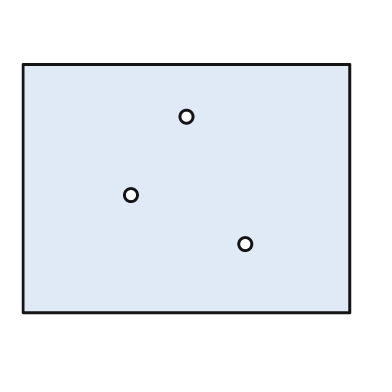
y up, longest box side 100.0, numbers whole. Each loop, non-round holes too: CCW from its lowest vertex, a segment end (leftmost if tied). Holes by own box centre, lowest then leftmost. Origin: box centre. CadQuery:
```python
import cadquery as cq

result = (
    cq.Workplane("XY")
    .moveTo(-50.0, -38.0)
    .lineTo(50.0, -38.0)
    .lineTo(50.0, 38.0)
    .lineTo(-50.0, 38.0)
    .close()
    .moveTo(18.0, -17.0)
    .circle(2.0)
    .moveTo(-17.0, -2.0)
    .circle(2.0)
    .moveTo(0.0, 22.0)
    .circle(2.0)
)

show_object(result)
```